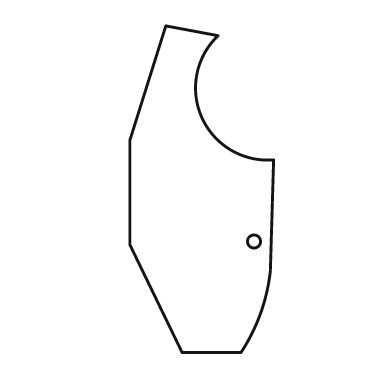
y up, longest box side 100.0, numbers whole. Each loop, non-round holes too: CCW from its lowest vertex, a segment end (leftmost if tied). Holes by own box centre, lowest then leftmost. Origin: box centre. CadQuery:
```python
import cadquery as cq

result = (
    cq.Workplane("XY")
    .moveTo(-6.0, -50.0)
    .lineTo(12.0, -50.0)
    .threePointArc((18.0, -38.0), (21.0, -25.0))
    .lineTo(22.0, 9.0)
    .threePointArc((0.0, 22.0), (5.0, 47.0))
    .lineTo(-11.0, 50.0)
    .lineTo(-22.0, 15.0)
    .lineTo(-22.0, -17.0)
    .close()
    .moveTo(16.0, -16.0)
    .circle(2.0)
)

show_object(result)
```